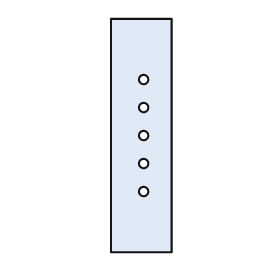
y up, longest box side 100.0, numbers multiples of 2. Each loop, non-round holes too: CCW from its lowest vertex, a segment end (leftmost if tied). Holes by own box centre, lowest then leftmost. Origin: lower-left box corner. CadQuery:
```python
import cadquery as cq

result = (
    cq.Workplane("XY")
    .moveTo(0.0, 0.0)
    .lineTo(26.0, 0.0)
    .lineTo(26.0, 100.0)
    .lineTo(0.0, 100.0)
    .close()
    .moveTo(14.0, 26.0)
    .circle(2.0)
    .moveTo(14.0, 38.0)
    .circle(2.0)
    .moveTo(14.0, 50.0)
    .circle(2.0)
    .moveTo(14.0, 62.0)
    .circle(2.0)
    .moveTo(14.0, 74.0)
    .circle(2.0)
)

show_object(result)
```